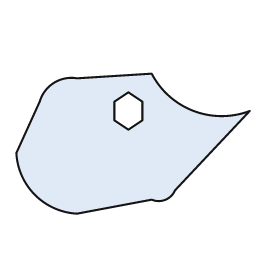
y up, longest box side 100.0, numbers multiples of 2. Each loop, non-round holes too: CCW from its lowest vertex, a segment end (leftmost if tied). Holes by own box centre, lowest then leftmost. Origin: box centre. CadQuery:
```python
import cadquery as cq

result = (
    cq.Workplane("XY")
    .moveTo(-24.0, -30.0)
    .lineTo(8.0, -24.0)
    .threePointArc((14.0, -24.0), (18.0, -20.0))
    .lineTo(50.0, 14.0)
    .threePointArc((26.0, 14.0), (8.0, 30.0))
    .lineTo(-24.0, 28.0)
    .threePointArc((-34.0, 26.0), (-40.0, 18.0))
    .lineTo(-50.0, -4.0)
    .threePointArc((-42.0, -22.0), (-24.0, -30.0))
    .close()
    .moveTo(-2.0, 6.0)
    .lineTo(4.0, 10.0)
    .lineTo(4.0, 18.0)
    .lineTo(-2.0, 22.0)
    .lineTo(-8.0, 18.0)
    .lineTo(-8.0, 10.0)
    .close()
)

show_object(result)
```